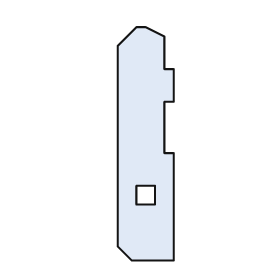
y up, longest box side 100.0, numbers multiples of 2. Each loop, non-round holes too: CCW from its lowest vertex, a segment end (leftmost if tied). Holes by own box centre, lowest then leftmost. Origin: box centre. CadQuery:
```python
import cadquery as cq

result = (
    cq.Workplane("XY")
    .moveTo(-6.0, -50.0)
    .lineTo(12.0, -50.0)
    .lineTo(12.0, -4.0)
    .lineTo(8.0, -4.0)
    .lineTo(8.0, 18.0)
    .lineTo(12.0, 18.0)
    .lineTo(12.0, 32.0)
    .lineTo(8.0, 32.0)
    .lineTo(8.0, 46.0)
    .lineTo(0.0, 50.0)
    .lineTo(-4.0, 50.0)
    .lineTo(-12.0, 42.0)
    .lineTo(-12.0, -44.0)
    .close()
    .moveTo(-4.0, -26.0)
    .lineTo(4.0, -26.0)
    .lineTo(4.0, -18.0)
    .lineTo(-4.0, -18.0)
    .close()
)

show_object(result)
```